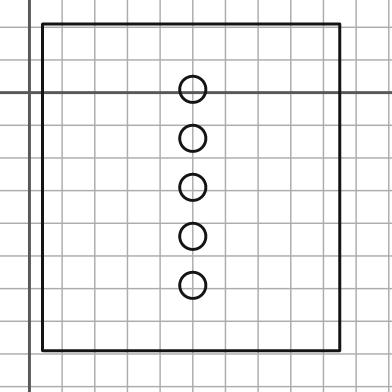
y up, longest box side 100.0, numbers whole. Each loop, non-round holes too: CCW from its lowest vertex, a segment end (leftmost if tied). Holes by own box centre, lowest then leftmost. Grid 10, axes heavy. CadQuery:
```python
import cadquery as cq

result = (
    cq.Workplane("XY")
    .moveTo(4.0, -79.0)
    .lineTo(95.0, -79.0)
    .lineTo(95.0, 21.0)
    .lineTo(4.0, 21.0)
    .close()
    .moveTo(50.0, -59.0)
    .circle(4.0)
    .moveTo(50.0, -44.0)
    .circle(4.0)
    .moveTo(50.0, -29.0)
    .circle(4.0)
    .moveTo(50.0, -14.0)
    .circle(4.0)
    .moveTo(50.0, 1.0)
    .circle(4.0)
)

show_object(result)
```